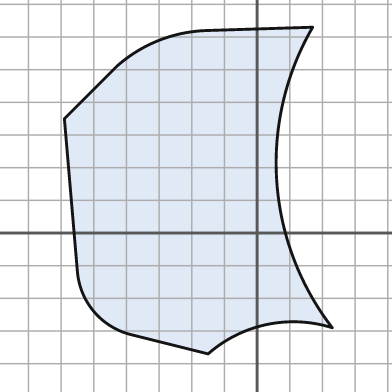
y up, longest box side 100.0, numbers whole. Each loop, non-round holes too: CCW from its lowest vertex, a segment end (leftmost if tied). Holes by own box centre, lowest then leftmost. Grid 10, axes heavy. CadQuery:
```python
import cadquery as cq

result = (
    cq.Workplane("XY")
    .moveTo(-15.0, -37.0)
    .threePointArc((3.0, -28.0), (23.0, -29.0))
    .threePointArc((6.0, 16.0), (17.0, 63.0))
    .lineTo(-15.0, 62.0)
    .threePointArc((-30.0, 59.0), (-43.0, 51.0))
    .lineTo(-59.0, 35.0)
    .lineTo(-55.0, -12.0)
    .threePointArc((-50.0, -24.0), (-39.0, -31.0))
    .close()
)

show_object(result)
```